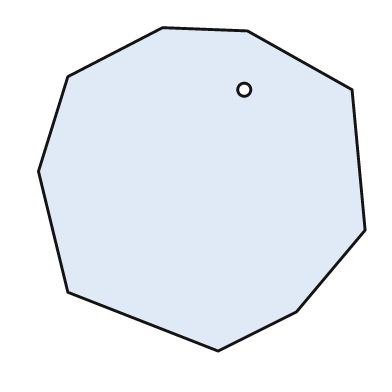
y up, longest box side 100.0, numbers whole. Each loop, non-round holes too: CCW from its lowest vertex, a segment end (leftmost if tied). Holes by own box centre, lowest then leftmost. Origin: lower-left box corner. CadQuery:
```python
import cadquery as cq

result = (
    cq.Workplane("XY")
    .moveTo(55.0, 0.0)
    .lineTo(79.0, 12.0)
    .lineTo(100.0, 37.0)
    .lineTo(96.0, 80.0)
    .lineTo(64.0, 98.0)
    .lineTo(38.0, 99.0)
    .lineTo(9.0, 84.0)
    .lineTo(0.0, 55.0)
    .lineTo(9.0, 18.0)
    .close()
    .moveTo(63.0, 80.0)
    .circle(2.0)
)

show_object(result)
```